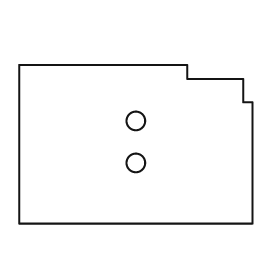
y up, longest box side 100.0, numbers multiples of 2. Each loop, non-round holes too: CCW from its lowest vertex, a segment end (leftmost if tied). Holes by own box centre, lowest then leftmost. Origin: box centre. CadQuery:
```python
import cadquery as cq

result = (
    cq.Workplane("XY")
    .moveTo(-50.0, -34.0)
    .lineTo(50.0, -34.0)
    .lineTo(50.0, 18.0)
    .lineTo(46.0, 18.0)
    .lineTo(46.0, 28.0)
    .lineTo(22.0, 28.0)
    .lineTo(22.0, 34.0)
    .lineTo(-50.0, 34.0)
    .close()
    .moveTo(0.0, -8.0)
    .circle(4.0)
    .moveTo(0.0, 10.0)
    .circle(4.0)
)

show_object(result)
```